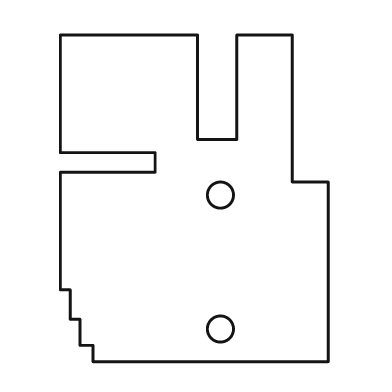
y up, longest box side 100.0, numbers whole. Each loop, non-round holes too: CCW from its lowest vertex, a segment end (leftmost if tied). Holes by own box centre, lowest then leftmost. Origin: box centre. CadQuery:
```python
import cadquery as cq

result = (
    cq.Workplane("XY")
    .moveTo(-31.0, -50.0)
    .lineTo(41.0, -50.0)
    .lineTo(41.0, 5.0)
    .lineTo(30.0, 5.0)
    .lineTo(30.0, 50.0)
    .lineTo(13.0, 50.0)
    .lineTo(13.0, 18.0)
    .lineTo(1.0, 18.0)
    .lineTo(1.0, 50.0)
    .lineTo(-41.0, 50.0)
    .lineTo(-41.0, 14.0)
    .lineTo(-12.0, 14.0)
    .lineTo(-12.0, 8.0)
    .lineTo(-41.0, 8.0)
    .lineTo(-41.0, -28.0)
    .lineTo(-38.0, -28.0)
    .lineTo(-38.0, -37.0)
    .lineTo(-35.0, -37.0)
    .lineTo(-35.0, -45.0)
    .lineTo(-31.0, -45.0)
    .close()
    .moveTo(8.0, -40.0)
    .circle(4.0)
    .moveTo(8.0, 1.0)
    .circle(4.0)
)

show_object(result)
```